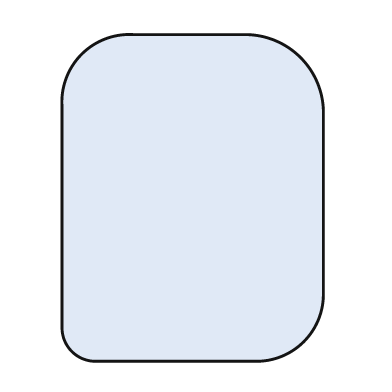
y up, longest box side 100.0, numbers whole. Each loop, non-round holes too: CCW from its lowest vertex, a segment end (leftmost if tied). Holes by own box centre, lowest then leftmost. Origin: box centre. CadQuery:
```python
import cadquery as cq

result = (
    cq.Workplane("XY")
    .moveTo(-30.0, -50.0)
    .lineTo(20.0, -50.0)
    .threePointArc((34.0, -44.0), (40.0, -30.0))
    .lineTo(40.0, 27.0)
    .threePointArc((33.0, 43.0), (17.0, 50.0))
    .lineTo(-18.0, 50.0)
    .threePointArc((-34.0, 44.0), (-40.0, 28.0))
    .lineTo(-40.0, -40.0)
    .threePointArc((-37.0, -47.0), (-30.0, -50.0))
    .close()
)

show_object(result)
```